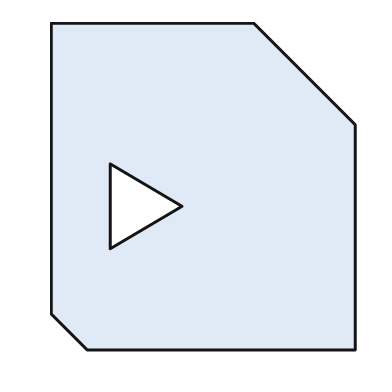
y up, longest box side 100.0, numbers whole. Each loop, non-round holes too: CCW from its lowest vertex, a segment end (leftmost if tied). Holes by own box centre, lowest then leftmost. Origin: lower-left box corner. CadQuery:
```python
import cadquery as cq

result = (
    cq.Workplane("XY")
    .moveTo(11.0, 0.0)
    .lineTo(93.0, 0.0)
    .lineTo(93.0, 69.0)
    .lineTo(62.0, 100.0)
    .lineTo(0.0, 100.0)
    .lineTo(0.0, 11.0)
    .close()
    .moveTo(18.0, 31.0)
    .lineTo(40.0, 44.0)
    .lineTo(18.0, 57.0)
    .close()
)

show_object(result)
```